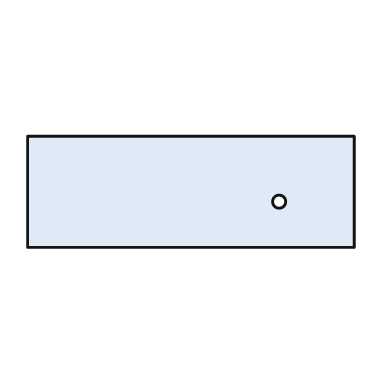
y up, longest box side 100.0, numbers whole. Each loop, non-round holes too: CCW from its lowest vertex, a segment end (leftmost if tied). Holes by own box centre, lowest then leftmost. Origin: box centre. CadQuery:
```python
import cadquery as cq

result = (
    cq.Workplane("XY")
    .moveTo(-50.0, -17.0)
    .lineTo(50.0, -17.0)
    .lineTo(50.0, 17.0)
    .lineTo(-50.0, 17.0)
    .close()
    .moveTo(27.0, -3.0)
    .circle(2.0)
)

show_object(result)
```